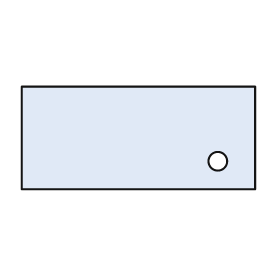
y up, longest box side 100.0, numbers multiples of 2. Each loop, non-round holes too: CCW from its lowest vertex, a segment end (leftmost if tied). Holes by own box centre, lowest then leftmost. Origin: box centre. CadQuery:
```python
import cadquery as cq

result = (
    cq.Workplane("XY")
    .moveTo(-50.0, -22.0)
    .lineTo(50.0, -22.0)
    .lineTo(50.0, 22.0)
    .lineTo(-50.0, 22.0)
    .close()
    .moveTo(34.0, -10.0)
    .circle(4.0)
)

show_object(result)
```